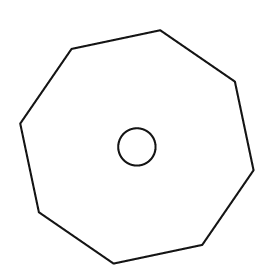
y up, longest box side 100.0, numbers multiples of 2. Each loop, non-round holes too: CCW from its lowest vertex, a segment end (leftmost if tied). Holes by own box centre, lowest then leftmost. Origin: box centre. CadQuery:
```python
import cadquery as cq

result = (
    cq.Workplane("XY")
    .moveTo(-10.0, -50.0)
    .lineTo(28.0, -42.0)
    .lineTo(50.0, -10.0)
    .lineTo(42.0, 28.0)
    .lineTo(10.0, 50.0)
    .lineTo(-28.0, 42.0)
    .lineTo(-50.0, 10.0)
    .lineTo(-42.0, -28.0)
    .close()
    .moveTo(0.0, 0.0)
    .circle(8.0)
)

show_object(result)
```